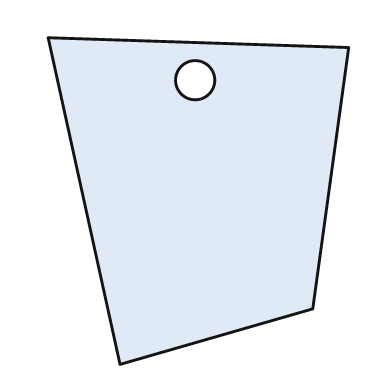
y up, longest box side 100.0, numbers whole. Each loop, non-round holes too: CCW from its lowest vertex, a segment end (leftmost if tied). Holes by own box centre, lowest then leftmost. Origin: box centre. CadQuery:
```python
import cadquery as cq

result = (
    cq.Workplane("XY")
    .moveTo(-24.0, -50.0)
    .lineTo(35.0, -33.0)
    .lineTo(46.0, 47.0)
    .lineTo(-46.0, 50.0)
    .close()
    .moveTo(-1.0, 37.0)
    .circle(6.0)
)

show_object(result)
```